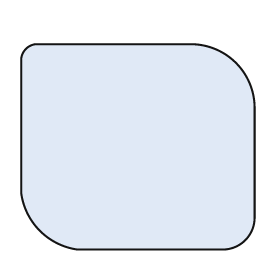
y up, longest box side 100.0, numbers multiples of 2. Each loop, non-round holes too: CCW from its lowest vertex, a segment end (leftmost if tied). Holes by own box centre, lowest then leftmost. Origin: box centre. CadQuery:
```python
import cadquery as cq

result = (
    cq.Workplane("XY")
    .moveTo(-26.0, -44.0)
    .lineTo(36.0, -44.0)
    .threePointArc((46.0, -40.0), (50.0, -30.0))
    .lineTo(50.0, 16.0)
    .threePointArc((42.0, 36.0), (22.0, 44.0))
    .lineTo(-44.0, 44.0)
    .threePointArc((-48.0, 42.0), (-50.0, 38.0))
    .lineTo(-50.0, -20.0)
    .threePointArc((-42.0, -36.0), (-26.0, -44.0))
    .close()
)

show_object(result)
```